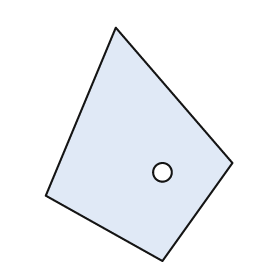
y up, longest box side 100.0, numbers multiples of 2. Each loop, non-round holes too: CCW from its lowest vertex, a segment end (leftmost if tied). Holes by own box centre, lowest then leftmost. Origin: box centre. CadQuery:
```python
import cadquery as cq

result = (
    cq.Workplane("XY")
    .moveTo(10.0, -50.0)
    .lineTo(40.0, -8.0)
    .lineTo(-10.0, 50.0)
    .lineTo(-40.0, -22.0)
    .close()
    .moveTo(10.0, -12.0)
    .circle(4.0)
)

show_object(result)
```